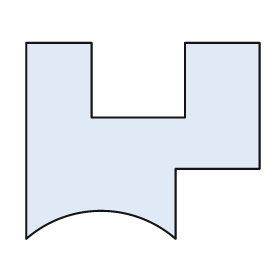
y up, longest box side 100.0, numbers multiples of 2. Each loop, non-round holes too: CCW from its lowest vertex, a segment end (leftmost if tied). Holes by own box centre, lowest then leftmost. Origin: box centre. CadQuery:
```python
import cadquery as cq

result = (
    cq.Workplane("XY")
    .moveTo(-50.0, -42.0)
    .threePointArc((-18.0, -30.0), (14.0, -42.0))
    .lineTo(14.0, -12.0)
    .lineTo(50.0, -12.0)
    .lineTo(50.0, 42.0)
    .lineTo(18.0, 42.0)
    .lineTo(18.0, 10.0)
    .lineTo(-22.0, 10.0)
    .lineTo(-22.0, 42.0)
    .lineTo(-50.0, 42.0)
    .close()
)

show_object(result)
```